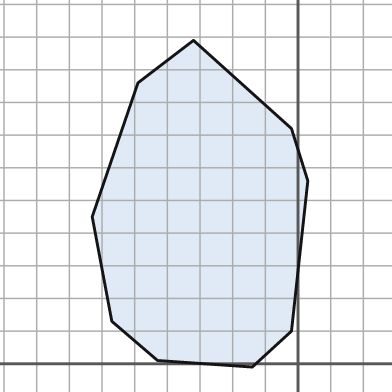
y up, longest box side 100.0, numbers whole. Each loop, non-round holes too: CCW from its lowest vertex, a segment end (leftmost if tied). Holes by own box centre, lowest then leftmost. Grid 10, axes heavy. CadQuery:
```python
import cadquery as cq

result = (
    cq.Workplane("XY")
    .moveTo(-14.0, -1.0)
    .lineTo(-2.0, 10.0)
    .lineTo(3.0, 56.0)
    .lineTo(-2.0, 72.0)
    .lineTo(-32.0, 99.0)
    .lineTo(-49.0, 86.0)
    .lineTo(-63.0, 45.0)
    .lineTo(-57.0, 13.0)
    .lineTo(-43.0, 1.0)
    .close()
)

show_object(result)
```